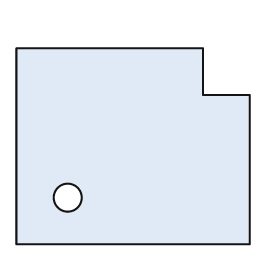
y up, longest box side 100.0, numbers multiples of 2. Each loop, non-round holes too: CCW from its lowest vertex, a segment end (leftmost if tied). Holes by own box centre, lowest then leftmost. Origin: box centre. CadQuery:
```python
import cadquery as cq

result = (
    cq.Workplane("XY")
    .moveTo(-50.0, -42.0)
    .lineTo(50.0, -42.0)
    .lineTo(50.0, 22.0)
    .lineTo(30.0, 22.0)
    .lineTo(30.0, 42.0)
    .lineTo(-50.0, 42.0)
    .close()
    .moveTo(-28.0, -22.0)
    .circle(6.0)
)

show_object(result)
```